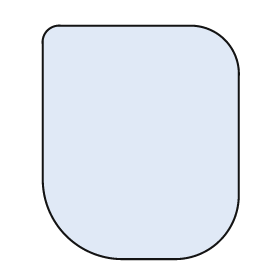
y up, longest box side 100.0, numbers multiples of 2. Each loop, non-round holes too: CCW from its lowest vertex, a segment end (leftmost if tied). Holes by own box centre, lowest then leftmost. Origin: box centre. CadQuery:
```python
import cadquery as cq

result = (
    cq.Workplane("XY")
    .moveTo(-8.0, -50.0)
    .lineTo(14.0, -50.0)
    .threePointArc((34.0, -42.0), (42.0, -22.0))
    .lineTo(42.0, 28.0)
    .threePointArc((36.0, 44.0), (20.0, 50.0))
    .lineTo(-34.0, 50.0)
    .threePointArc((-40.0, 48.0), (-42.0, 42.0))
    .lineTo(-42.0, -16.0)
    .threePointArc((-32.0, -40.0), (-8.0, -50.0))
    .close()
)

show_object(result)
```